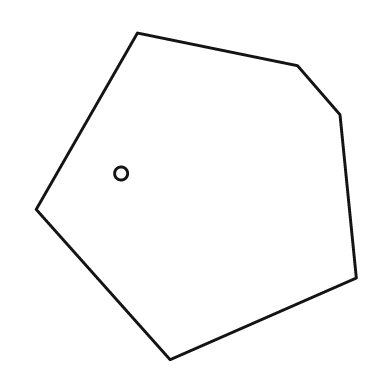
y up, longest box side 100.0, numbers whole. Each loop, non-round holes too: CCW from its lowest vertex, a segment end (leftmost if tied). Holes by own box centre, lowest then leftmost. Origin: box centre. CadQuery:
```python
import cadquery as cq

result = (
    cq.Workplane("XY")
    .moveTo(-8.0, -50.0)
    .lineTo(49.0, -25.0)
    .lineTo(44.0, 25.0)
    .lineTo(31.0, 40.0)
    .lineTo(-18.0, 50.0)
    .lineTo(-49.0, -4.0)
    .close()
    .moveTo(-23.0, 7.0)
    .circle(2.0)
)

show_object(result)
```